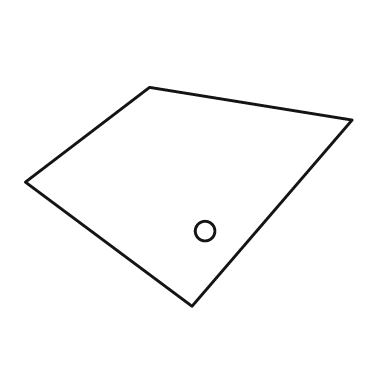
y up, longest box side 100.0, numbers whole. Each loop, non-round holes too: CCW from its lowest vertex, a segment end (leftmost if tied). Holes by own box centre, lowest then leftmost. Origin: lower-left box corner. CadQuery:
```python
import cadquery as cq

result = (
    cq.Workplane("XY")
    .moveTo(51.0, 0.0)
    .lineTo(100.0, 57.0)
    .lineTo(38.0, 67.0)
    .lineTo(0.0, 38.0)
    .close()
    .moveTo(55.0, 23.0)
    .circle(3.0)
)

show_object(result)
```